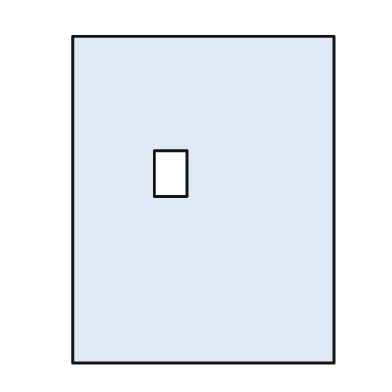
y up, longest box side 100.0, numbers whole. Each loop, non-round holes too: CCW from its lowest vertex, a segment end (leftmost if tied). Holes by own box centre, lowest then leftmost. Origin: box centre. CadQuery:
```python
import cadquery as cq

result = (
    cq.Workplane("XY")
    .moveTo(-40.0, -50.0)
    .lineTo(40.0, -50.0)
    .lineTo(40.0, 50.0)
    .lineTo(-40.0, 50.0)
    .close()
    .moveTo(-15.0, 1.0)
    .lineTo(-5.0, 1.0)
    .lineTo(-5.0, 15.0)
    .lineTo(-15.0, 15.0)
    .close()
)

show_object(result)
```